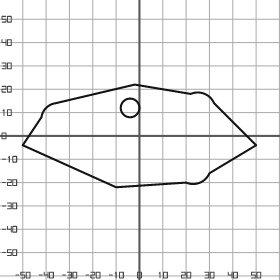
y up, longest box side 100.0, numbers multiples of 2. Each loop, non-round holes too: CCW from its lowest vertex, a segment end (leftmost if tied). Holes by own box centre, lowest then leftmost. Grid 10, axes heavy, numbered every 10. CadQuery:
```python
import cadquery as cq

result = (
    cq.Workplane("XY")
    .moveTo(-10.0, -22.0)
    .lineTo(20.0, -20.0)
    .threePointArc((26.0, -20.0), (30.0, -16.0))
    .lineTo(50.0, -4.0)
    .lineTo(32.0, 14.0)
    .threePointArc((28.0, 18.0), (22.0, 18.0))
    .lineTo(-2.0, 22.0)
    .lineTo(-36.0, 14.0)
    .threePointArc((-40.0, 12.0), (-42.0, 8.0))
    .lineTo(-50.0, -4.0)
    .close()
    .moveTo(-4.0, 12.0)
    .circle(4.0)
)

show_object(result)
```